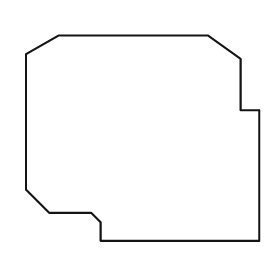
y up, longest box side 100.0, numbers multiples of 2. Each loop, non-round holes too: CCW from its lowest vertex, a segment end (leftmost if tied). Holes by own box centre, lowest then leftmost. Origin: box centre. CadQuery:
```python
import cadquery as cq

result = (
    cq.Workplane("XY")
    .moveTo(-18.0, -44.0)
    .lineTo(50.0, -44.0)
    .lineTo(50.0, 12.0)
    .lineTo(42.0, 12.0)
    .lineTo(42.0, 34.0)
    .lineTo(28.0, 44.0)
    .lineTo(-36.0, 44.0)
    .lineTo(-50.0, 36.0)
    .lineTo(-50.0, -22.0)
    .lineTo(-40.0, -32.0)
    .lineTo(-22.0, -32.0)
    .lineTo(-18.0, -36.0)
    .close()
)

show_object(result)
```